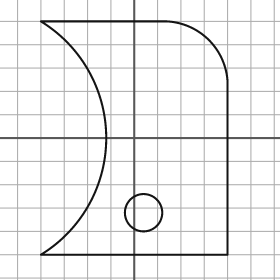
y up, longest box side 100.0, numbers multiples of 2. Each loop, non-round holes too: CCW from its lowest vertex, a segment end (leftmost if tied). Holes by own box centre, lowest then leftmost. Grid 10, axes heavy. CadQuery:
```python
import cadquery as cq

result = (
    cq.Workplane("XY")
    .moveTo(-40.0, -50.0)
    .lineTo(40.0, -50.0)
    .lineTo(40.0, 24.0)
    .threePointArc((32.0, 42.0), (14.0, 50.0))
    .lineTo(-40.0, 50.0)
    .threePointArc((-12.0, 0.0), (-40.0, -50.0))
    .close()
    .moveTo(4.0, -32.0)
    .circle(8.0)
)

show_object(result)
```